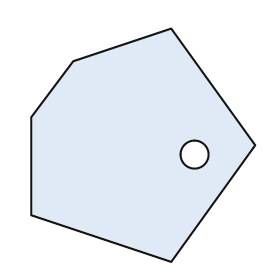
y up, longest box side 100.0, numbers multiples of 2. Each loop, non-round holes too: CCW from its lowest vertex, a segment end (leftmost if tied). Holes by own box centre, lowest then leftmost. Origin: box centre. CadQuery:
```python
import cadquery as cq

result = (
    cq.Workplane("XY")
    .moveTo(12.0, -50.0)
    .lineTo(48.0, 0.0)
    .lineTo(12.0, 50.0)
    .lineTo(-30.0, 36.0)
    .lineTo(-48.0, 12.0)
    .lineTo(-48.0, -30.0)
    .close()
    .moveTo(22.0, -4.0)
    .circle(6.0)
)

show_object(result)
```